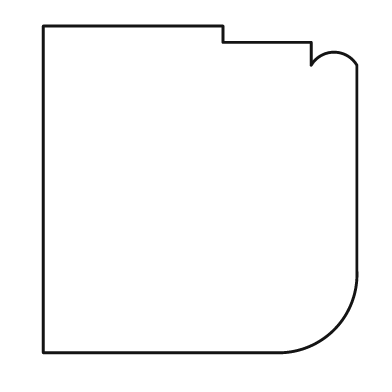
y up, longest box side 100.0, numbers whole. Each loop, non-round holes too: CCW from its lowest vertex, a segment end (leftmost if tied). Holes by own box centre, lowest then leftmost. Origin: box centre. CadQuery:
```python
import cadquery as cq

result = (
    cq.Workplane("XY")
    .moveTo(-48.0, -50.0)
    .lineTo(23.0, -50.0)
    .threePointArc((41.0, -43.0), (48.0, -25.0))
    .lineTo(48.0, 38.0)
    .threePointArc((41.0, 42.0), (34.0, 38.0))
    .lineTo(34.0, 45.0)
    .lineTo(7.0, 45.0)
    .lineTo(7.0, 50.0)
    .lineTo(-48.0, 50.0)
    .close()
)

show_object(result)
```